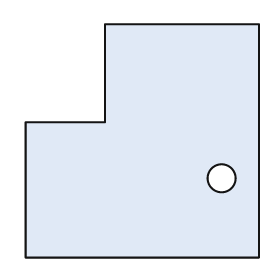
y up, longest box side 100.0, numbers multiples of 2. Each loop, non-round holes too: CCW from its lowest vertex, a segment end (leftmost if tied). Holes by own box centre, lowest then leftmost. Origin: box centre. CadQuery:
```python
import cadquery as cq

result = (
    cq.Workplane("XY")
    .moveTo(-50.0, -50.0)
    .lineTo(50.0, -50.0)
    .lineTo(50.0, 50.0)
    .lineTo(-16.0, 50.0)
    .lineTo(-16.0, 8.0)
    .lineTo(-50.0, 8.0)
    .close()
    .moveTo(34.0, -16.0)
    .circle(6.0)
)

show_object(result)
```